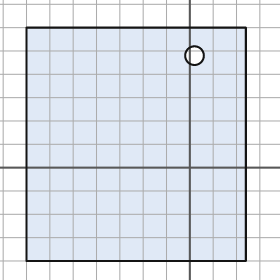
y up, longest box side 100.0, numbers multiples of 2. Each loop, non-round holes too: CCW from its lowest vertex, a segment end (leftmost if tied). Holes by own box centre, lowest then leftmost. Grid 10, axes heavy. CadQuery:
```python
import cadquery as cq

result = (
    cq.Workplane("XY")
    .moveTo(-70.0, -40.0)
    .lineTo(24.0, -40.0)
    .lineTo(24.0, 60.0)
    .lineTo(-70.0, 60.0)
    .close()
    .moveTo(2.0, 48.0)
    .circle(4.0)
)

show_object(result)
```